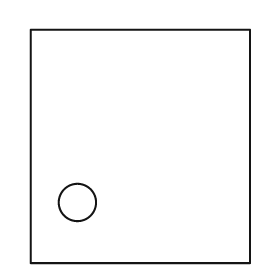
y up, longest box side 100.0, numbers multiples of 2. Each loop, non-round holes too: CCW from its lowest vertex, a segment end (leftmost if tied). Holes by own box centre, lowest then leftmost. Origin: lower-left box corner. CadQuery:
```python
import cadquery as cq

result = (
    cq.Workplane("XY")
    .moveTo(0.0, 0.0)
    .lineTo(94.0, 0.0)
    .lineTo(94.0, 100.0)
    .lineTo(0.0, 100.0)
    .close()
    .moveTo(20.0, 26.0)
    .circle(8.0)
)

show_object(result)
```